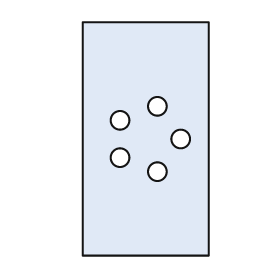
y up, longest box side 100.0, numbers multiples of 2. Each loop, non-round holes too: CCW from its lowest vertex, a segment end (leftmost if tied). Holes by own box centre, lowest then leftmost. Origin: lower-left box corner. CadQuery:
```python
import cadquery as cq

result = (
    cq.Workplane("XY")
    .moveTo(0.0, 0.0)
    .lineTo(54.0, 0.0)
    .lineTo(54.0, 100.0)
    .lineTo(0.0, 100.0)
    .close()
    .moveTo(32.0, 36.0)
    .circle(4.0)
    .moveTo(16.0, 42.0)
    .circle(4.0)
    .moveTo(42.0, 50.0)
    .circle(4.0)
    .moveTo(16.0, 58.0)
    .circle(4.0)
    .moveTo(32.0, 64.0)
    .circle(4.0)
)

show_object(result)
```